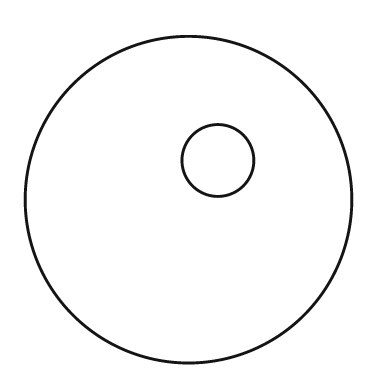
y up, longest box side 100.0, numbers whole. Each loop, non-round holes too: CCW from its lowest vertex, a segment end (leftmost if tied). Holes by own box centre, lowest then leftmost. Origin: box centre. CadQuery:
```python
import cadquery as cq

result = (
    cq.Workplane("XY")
    .moveTo(0.0, 0.0)
    .circle(50.0)
    .moveTo(9.0, 12.0)
    .circle(11.0)
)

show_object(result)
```